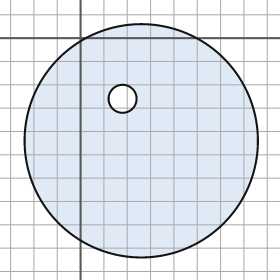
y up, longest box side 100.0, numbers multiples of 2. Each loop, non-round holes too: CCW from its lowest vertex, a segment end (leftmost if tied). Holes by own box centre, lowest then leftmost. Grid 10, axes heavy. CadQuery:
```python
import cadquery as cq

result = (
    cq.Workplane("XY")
    .moveTo(26.0, -44.0)
    .circle(50.0)
    .moveTo(18.0, -26.0)
    .circle(6.0)
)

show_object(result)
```